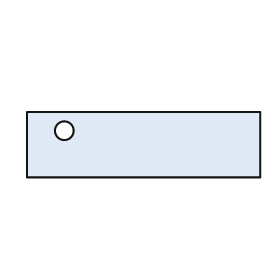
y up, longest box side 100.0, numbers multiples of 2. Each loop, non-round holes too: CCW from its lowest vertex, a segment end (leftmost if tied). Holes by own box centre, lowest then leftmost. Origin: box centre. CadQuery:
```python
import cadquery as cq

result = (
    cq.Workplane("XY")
    .moveTo(-50.0, -14.0)
    .lineTo(50.0, -14.0)
    .lineTo(50.0, 14.0)
    .lineTo(-50.0, 14.0)
    .close()
    .moveTo(-34.0, 6.0)
    .circle(4.0)
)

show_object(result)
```